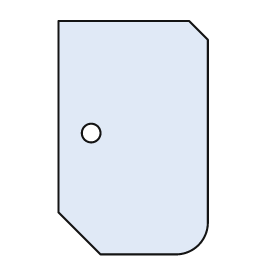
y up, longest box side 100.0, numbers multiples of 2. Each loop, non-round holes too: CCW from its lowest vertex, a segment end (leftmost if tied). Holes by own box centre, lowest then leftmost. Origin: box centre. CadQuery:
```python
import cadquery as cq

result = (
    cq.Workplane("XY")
    .moveTo(-14.0, -50.0)
    .lineTo(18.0, -50.0)
    .threePointArc((28.0, -46.0), (32.0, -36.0))
    .lineTo(32.0, 42.0)
    .lineTo(24.0, 50.0)
    .lineTo(-32.0, 50.0)
    .lineTo(-32.0, -32.0)
    .close()
    .moveTo(-18.0, 2.0)
    .circle(4.0)
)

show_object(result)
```